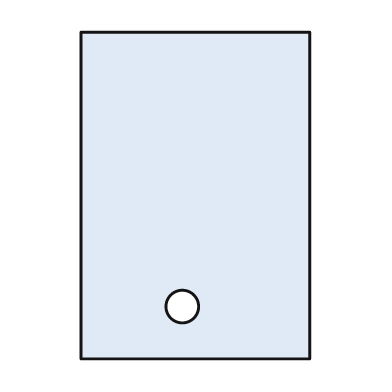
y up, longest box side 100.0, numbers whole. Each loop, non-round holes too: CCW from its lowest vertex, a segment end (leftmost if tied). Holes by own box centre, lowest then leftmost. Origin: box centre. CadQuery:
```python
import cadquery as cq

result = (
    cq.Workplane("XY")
    .moveTo(-35.0, -50.0)
    .lineTo(35.0, -50.0)
    .lineTo(35.0, 50.0)
    .lineTo(-35.0, 50.0)
    .close()
    .moveTo(-4.0, -34.0)
    .circle(5.0)
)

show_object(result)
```